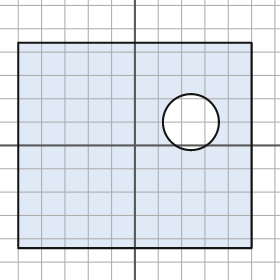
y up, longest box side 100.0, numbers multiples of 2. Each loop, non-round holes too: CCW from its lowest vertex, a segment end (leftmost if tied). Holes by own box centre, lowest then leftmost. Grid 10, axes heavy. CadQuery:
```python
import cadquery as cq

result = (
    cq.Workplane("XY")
    .moveTo(-50.0, -44.0)
    .lineTo(50.0, -44.0)
    .lineTo(50.0, 44.0)
    .lineTo(-50.0, 44.0)
    .close()
    .moveTo(24.0, 10.0)
    .circle(12.0)
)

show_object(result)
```